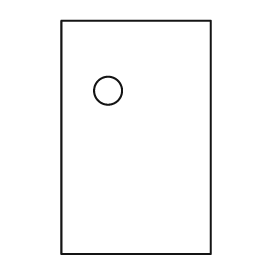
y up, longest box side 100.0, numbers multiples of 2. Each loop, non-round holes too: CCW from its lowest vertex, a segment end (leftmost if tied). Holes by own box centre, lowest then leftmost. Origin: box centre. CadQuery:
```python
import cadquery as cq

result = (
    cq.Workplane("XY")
    .moveTo(-32.0, -50.0)
    .lineTo(32.0, -50.0)
    .lineTo(32.0, 50.0)
    .lineTo(-32.0, 50.0)
    .close()
    .moveTo(-12.0, 20.0)
    .circle(6.0)
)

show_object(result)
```